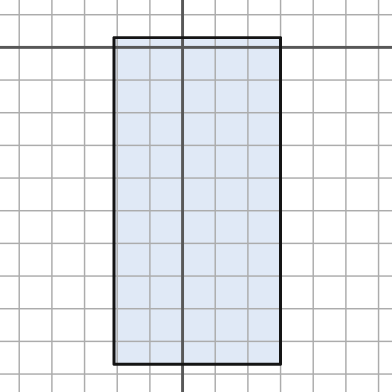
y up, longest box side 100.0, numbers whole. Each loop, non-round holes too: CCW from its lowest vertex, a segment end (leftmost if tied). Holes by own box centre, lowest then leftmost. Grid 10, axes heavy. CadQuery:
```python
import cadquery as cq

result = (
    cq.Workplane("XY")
    .moveTo(-21.0, -97.0)
    .lineTo(30.0, -97.0)
    .lineTo(30.0, 3.0)
    .lineTo(-21.0, 3.0)
    .close()
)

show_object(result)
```